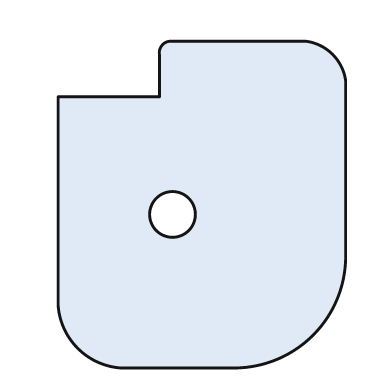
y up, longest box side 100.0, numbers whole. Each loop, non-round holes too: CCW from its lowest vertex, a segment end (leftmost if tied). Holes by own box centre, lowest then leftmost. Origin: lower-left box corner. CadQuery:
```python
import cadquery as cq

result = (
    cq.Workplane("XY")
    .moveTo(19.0, 0.0)
    .lineTo(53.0, 0.0)
    .threePointArc((78.0, 10.0), (88.0, 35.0))
    .lineTo(88.0, 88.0)
    .threePointArc((84.0, 96.0), (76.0, 100.0))
    .lineTo(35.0, 100.0)
    .threePointArc((32.0, 99.0), (31.0, 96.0))
    .lineTo(31.0, 83.0)
    .lineTo(0.0, 83.0)
    .lineTo(0.0, 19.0)
    .threePointArc((6.0, 6.0), (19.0, 0.0))
    .close()
    .moveTo(35.0, 47.0)
    .circle(7.0)
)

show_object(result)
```